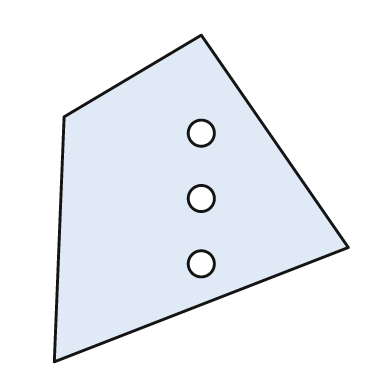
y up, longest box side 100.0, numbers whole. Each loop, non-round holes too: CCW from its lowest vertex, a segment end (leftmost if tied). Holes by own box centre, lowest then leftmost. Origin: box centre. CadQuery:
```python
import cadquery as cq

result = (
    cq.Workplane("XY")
    .moveTo(-45.0, -50.0)
    .lineTo(45.0, -15.0)
    .lineTo(0.0, 50.0)
    .lineTo(-42.0, 25.0)
    .close()
    .moveTo(0.0, -20.0)
    .circle(4.0)
    .moveTo(0.0, 0.0)
    .circle(4.0)
    .moveTo(0.0, 20.0)
    .circle(4.0)
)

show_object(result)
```